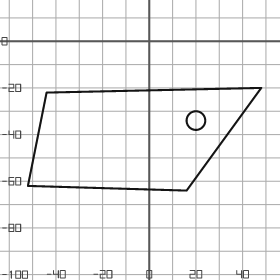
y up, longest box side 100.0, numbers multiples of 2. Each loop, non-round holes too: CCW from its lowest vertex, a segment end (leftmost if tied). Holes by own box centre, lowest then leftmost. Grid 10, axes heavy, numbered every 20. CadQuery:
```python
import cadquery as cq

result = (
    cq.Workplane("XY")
    .moveTo(16.0, -64.0)
    .lineTo(48.0, -20.0)
    .lineTo(-44.0, -22.0)
    .lineTo(-52.0, -62.0)
    .close()
    .moveTo(20.0, -34.0)
    .circle(4.0)
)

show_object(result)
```